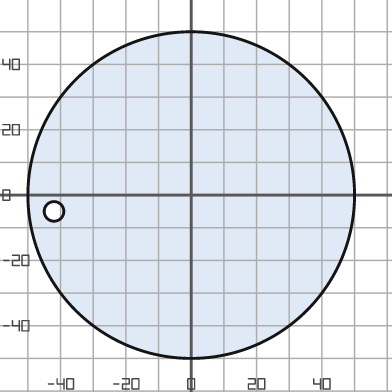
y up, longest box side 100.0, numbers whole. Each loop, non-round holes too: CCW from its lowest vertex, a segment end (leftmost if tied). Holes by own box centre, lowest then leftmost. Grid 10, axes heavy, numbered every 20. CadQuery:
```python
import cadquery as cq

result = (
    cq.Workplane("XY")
    .moveTo(0.0, 0.0)
    .circle(50.0)
    .moveTo(-42.0, -5.0)
    .circle(3.0)
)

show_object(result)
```